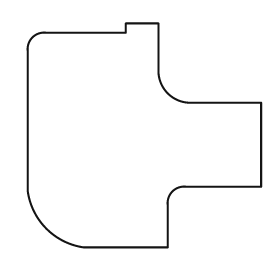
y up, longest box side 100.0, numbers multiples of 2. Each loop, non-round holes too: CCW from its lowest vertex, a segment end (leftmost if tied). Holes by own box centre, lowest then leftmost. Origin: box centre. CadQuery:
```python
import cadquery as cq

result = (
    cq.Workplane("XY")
    .moveTo(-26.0, -48.0)
    .lineTo(10.0, -48.0)
    .lineTo(10.0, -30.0)
    .threePointArc((12.0, -24.0), (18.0, -22.0))
    .lineTo(50.0, -22.0)
    .lineTo(50.0, 14.0)
    .lineTo(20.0, 14.0)
    .threePointArc((10.0, 18.0), (6.0, 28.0))
    .lineTo(6.0, 48.0)
    .lineTo(-8.0, 48.0)
    .lineTo(-8.0, 44.0)
    .lineTo(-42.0, 44.0)
    .threePointArc((-48.0, 42.0), (-50.0, 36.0))
    .lineTo(-50.0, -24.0)
    .threePointArc((-42.0, -40.0), (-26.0, -48.0))
    .close()
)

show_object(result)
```